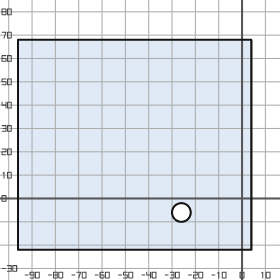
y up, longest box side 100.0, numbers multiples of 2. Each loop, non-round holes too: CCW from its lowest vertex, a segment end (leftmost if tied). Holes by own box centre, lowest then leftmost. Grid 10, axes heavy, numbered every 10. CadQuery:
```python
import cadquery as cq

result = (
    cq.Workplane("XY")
    .moveTo(-96.0, -22.0)
    .lineTo(4.0, -22.0)
    .lineTo(4.0, 68.0)
    .lineTo(-96.0, 68.0)
    .close()
    .moveTo(-26.0, -6.0)
    .circle(4.0)
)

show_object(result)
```